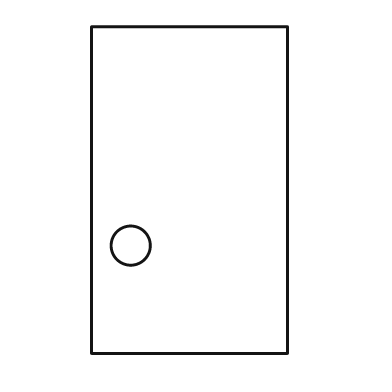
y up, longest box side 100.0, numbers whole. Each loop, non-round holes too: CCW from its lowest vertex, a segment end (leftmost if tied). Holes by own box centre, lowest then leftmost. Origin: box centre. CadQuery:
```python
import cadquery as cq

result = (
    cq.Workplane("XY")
    .moveTo(-30.0, -50.0)
    .lineTo(30.0, -50.0)
    .lineTo(30.0, 50.0)
    .lineTo(-30.0, 50.0)
    .close()
    .moveTo(-18.0, -17.0)
    .circle(6.0)
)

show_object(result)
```